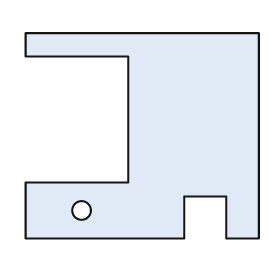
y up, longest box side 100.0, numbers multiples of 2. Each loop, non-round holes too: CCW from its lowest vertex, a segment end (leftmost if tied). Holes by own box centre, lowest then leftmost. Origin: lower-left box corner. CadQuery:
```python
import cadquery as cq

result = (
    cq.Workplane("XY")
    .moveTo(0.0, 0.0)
    .lineTo(68.0, 0.0)
    .lineTo(68.0, 18.0)
    .lineTo(86.0, 18.0)
    .lineTo(86.0, 0.0)
    .lineTo(100.0, 0.0)
    .lineTo(100.0, 88.0)
    .lineTo(0.0, 88.0)
    .lineTo(0.0, 78.0)
    .lineTo(44.0, 78.0)
    .lineTo(44.0, 24.0)
    .lineTo(0.0, 24.0)
    .close()
    .moveTo(24.0, 12.0)
    .circle(4.0)
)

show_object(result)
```